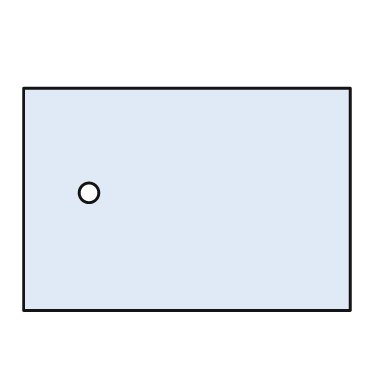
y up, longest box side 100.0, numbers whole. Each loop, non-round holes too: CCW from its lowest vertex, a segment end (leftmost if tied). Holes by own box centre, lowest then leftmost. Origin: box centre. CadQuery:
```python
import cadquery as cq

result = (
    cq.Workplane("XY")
    .moveTo(-50.0, -34.0)
    .lineTo(50.0, -34.0)
    .lineTo(50.0, 34.0)
    .lineTo(-50.0, 34.0)
    .close()
    .moveTo(-30.0, 2.0)
    .circle(3.0)
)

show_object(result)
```